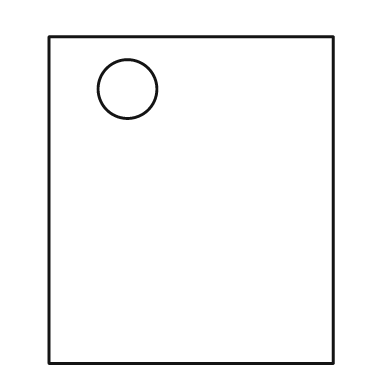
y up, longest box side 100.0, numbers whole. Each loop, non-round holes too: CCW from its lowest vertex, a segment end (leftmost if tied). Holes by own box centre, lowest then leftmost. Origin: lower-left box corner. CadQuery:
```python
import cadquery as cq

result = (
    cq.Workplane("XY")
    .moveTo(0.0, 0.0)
    .lineTo(87.0, 0.0)
    .lineTo(87.0, 100.0)
    .lineTo(0.0, 100.0)
    .close()
    .moveTo(24.0, 84.0)
    .circle(9.0)
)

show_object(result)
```